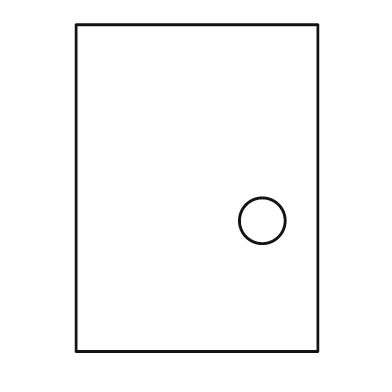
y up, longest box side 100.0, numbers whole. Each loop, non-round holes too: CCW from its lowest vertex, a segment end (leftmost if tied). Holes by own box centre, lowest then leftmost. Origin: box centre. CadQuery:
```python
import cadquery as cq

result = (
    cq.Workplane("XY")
    .moveTo(-37.0, -50.0)
    .lineTo(37.0, -50.0)
    .lineTo(37.0, 50.0)
    .lineTo(-37.0, 50.0)
    .close()
    .moveTo(20.0, -10.0)
    .circle(7.0)
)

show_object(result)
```